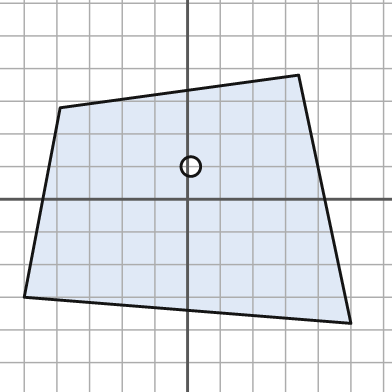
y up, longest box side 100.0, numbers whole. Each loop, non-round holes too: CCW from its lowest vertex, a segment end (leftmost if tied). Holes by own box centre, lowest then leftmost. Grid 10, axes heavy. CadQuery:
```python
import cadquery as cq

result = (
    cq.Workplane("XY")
    .moveTo(50.0, -38.0)
    .lineTo(34.0, 38.0)
    .lineTo(-39.0, 28.0)
    .lineTo(-50.0, -30.0)
    .close()
    .moveTo(1.0, 10.0)
    .circle(3.0)
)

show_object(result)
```